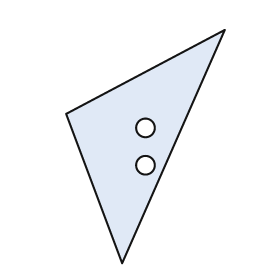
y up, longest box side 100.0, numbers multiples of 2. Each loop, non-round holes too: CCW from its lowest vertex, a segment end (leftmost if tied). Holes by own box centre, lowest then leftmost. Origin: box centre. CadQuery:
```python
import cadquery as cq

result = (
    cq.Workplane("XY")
    .moveTo(-10.0, -50.0)
    .lineTo(34.0, 50.0)
    .lineTo(-34.0, 14.0)
    .close()
    .moveTo(0.0, -8.0)
    .circle(4.0)
    .moveTo(0.0, 8.0)
    .circle(4.0)
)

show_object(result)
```